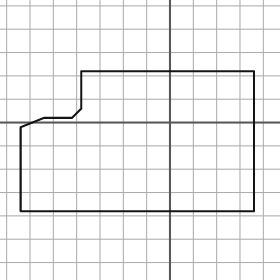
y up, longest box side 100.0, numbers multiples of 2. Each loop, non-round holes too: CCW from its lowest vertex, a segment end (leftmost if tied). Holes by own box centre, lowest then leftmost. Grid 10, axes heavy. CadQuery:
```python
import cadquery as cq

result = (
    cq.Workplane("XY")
    .moveTo(-64.0, -38.0)
    .lineTo(36.0, -38.0)
    .lineTo(36.0, 22.0)
    .lineTo(-38.0, 22.0)
    .lineTo(-38.0, 6.0)
    .lineTo(-42.0, 2.0)
    .lineTo(-54.0, 2.0)
    .lineTo(-64.0, -2.0)
    .close()
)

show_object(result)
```